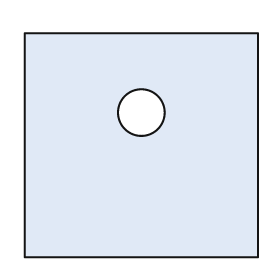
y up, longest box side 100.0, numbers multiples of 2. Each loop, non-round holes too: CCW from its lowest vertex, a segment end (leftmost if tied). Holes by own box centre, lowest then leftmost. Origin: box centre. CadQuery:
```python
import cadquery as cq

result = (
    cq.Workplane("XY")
    .moveTo(-50.0, -48.0)
    .lineTo(50.0, -48.0)
    .lineTo(50.0, 48.0)
    .lineTo(-50.0, 48.0)
    .close()
    .moveTo(0.0, 14.0)
    .circle(10.0)
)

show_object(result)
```